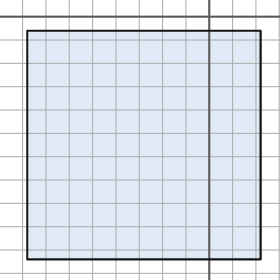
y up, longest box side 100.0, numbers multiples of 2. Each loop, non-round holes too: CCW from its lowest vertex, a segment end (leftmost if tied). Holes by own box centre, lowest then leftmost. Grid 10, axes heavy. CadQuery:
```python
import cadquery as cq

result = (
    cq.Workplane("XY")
    .moveTo(-78.0, -104.0)
    .lineTo(22.0, -104.0)
    .lineTo(22.0, -6.0)
    .lineTo(-78.0, -6.0)
    .close()
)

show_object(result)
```